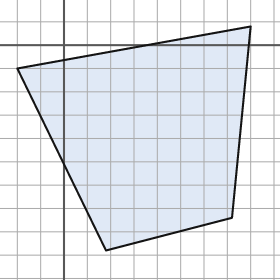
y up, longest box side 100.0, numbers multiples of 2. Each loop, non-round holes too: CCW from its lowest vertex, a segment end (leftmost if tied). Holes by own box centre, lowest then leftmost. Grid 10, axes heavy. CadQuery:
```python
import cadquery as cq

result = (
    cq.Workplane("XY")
    .moveTo(18.0, -88.0)
    .lineTo(72.0, -74.0)
    .lineTo(80.0, 8.0)
    .lineTo(-20.0, -10.0)
    .close()
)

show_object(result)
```